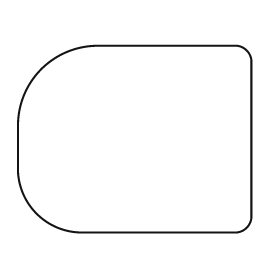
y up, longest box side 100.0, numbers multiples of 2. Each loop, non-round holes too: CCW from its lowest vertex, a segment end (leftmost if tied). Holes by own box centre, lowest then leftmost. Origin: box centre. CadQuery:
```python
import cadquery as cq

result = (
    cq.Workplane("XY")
    .moveTo(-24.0, -40.0)
    .lineTo(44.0, -40.0)
    .threePointArc((48.0, -38.0), (50.0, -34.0))
    .lineTo(50.0, 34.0)
    .threePointArc((48.0, 38.0), (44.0, 40.0))
    .lineTo(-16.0, 40.0)
    .threePointArc((-40.0, 30.0), (-50.0, 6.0))
    .lineTo(-50.0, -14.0)
    .threePointArc((-42.0, -32.0), (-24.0, -40.0))
    .close()
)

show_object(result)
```